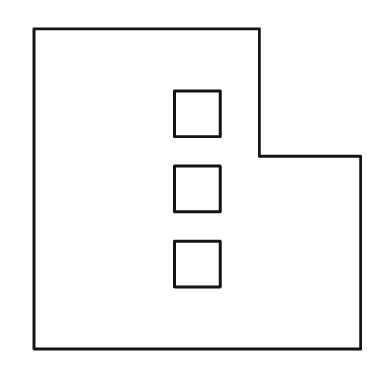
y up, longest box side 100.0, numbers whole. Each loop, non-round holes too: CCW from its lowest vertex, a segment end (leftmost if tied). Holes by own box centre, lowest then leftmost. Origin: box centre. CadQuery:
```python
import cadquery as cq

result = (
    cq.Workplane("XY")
    .moveTo(-50.0, -49.0)
    .lineTo(50.0, -49.0)
    .lineTo(50.0, 10.0)
    .lineTo(19.0, 10.0)
    .lineTo(19.0, 49.0)
    .lineTo(-50.0, 49.0)
    .close()
    .moveTo(-7.0, -30.0)
    .lineTo(7.0, -30.0)
    .lineTo(7.0, -16.0)
    .lineTo(-7.0, -16.0)
    .close()
    .moveTo(-7.0, -7.0)
    .lineTo(7.0, -7.0)
    .lineTo(7.0, 7.0)
    .lineTo(-7.0, 7.0)
    .close()
    .moveTo(-7.0, 16.0)
    .lineTo(7.0, 16.0)
    .lineTo(7.0, 30.0)
    .lineTo(-7.0, 30.0)
    .close()
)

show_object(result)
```